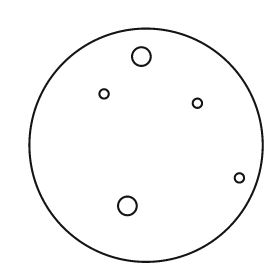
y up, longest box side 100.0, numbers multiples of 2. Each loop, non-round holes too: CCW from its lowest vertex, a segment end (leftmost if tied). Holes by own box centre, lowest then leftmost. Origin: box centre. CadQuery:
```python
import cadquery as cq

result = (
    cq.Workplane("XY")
    .moveTo(0.0, 0.0)
    .circle(50.0)
    .moveTo(-8.0, -26.0)
    .circle(4.0)
    .moveTo(40.0, -14.0)
    .circle(2.0)
    .moveTo(22.0, 18.0)
    .circle(2.0)
    .moveTo(-18.0, 22.0)
    .circle(2.0)
    .moveTo(-2.0, 38.0)
    .circle(4.0)
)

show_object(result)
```